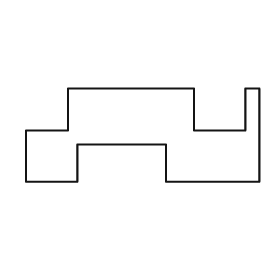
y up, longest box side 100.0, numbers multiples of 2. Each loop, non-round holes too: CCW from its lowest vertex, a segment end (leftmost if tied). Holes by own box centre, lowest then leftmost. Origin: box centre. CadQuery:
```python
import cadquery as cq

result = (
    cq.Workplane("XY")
    .moveTo(-50.0, -20.0)
    .lineTo(-28.0, -20.0)
    .lineTo(-28.0, -4.0)
    .lineTo(10.0, -4.0)
    .lineTo(10.0, -20.0)
    .lineTo(50.0, -20.0)
    .lineTo(50.0, 20.0)
    .lineTo(44.0, 20.0)
    .lineTo(44.0, 2.0)
    .lineTo(22.0, 2.0)
    .lineTo(22.0, 20.0)
    .lineTo(-32.0, 20.0)
    .lineTo(-32.0, 2.0)
    .lineTo(-50.0, 2.0)
    .close()
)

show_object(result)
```